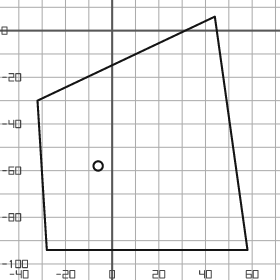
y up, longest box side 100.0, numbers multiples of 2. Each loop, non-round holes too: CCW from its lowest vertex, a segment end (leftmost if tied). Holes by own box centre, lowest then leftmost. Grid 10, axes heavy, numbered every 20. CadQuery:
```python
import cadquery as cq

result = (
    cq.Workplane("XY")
    .moveTo(-28.0, -94.0)
    .lineTo(58.0, -94.0)
    .lineTo(44.0, 6.0)
    .lineTo(-32.0, -30.0)
    .close()
    .moveTo(-6.0, -58.0)
    .circle(2.0)
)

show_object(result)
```